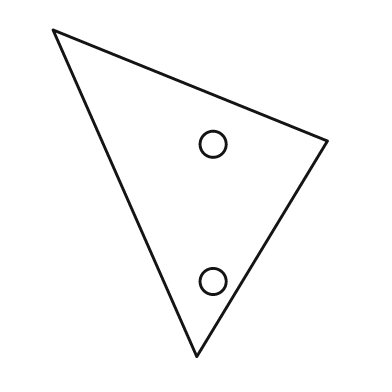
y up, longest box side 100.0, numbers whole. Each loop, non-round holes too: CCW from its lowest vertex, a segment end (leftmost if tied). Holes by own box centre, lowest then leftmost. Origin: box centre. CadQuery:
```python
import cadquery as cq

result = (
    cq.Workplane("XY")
    .moveTo(2.0, -50.0)
    .lineTo(42.0, 16.0)
    .lineTo(-42.0, 50.0)
    .close()
    .moveTo(7.0, -27.0)
    .circle(4.0)
    .moveTo(7.0, 15.0)
    .circle(4.0)
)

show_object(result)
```